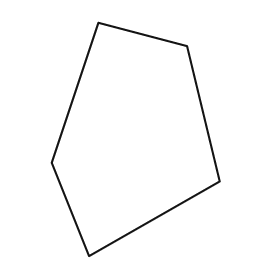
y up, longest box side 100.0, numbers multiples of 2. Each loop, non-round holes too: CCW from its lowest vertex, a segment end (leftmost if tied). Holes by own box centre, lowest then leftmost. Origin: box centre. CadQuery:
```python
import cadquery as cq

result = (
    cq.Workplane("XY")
    .moveTo(-20.0, -50.0)
    .lineTo(36.0, -18.0)
    .lineTo(22.0, 40.0)
    .lineTo(-16.0, 50.0)
    .lineTo(-36.0, -10.0)
    .close()
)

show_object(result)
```